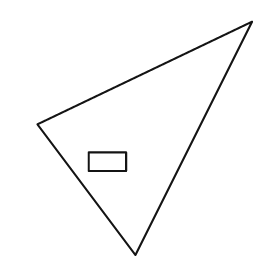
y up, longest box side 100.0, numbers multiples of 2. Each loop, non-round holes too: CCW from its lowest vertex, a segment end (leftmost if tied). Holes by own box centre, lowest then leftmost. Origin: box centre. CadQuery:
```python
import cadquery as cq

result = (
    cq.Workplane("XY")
    .moveTo(-4.0, -50.0)
    .lineTo(46.0, 50.0)
    .lineTo(-46.0, 6.0)
    .close()
    .moveTo(-24.0, -14.0)
    .lineTo(-8.0, -14.0)
    .lineTo(-8.0, -6.0)
    .lineTo(-24.0, -6.0)
    .close()
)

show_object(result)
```